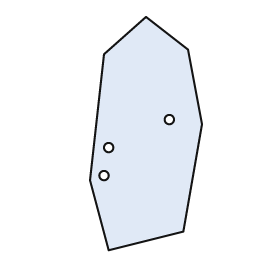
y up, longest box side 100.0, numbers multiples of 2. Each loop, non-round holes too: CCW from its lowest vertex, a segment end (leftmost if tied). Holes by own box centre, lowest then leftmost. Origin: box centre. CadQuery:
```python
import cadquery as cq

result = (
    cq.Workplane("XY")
    .moveTo(-16.0, -50.0)
    .lineTo(16.0, -42.0)
    .lineTo(24.0, 4.0)
    .lineTo(18.0, 36.0)
    .lineTo(0.0, 50.0)
    .lineTo(-18.0, 34.0)
    .lineTo(-24.0, -20.0)
    .close()
    .moveTo(-18.0, -18.0)
    .circle(2.0)
    .moveTo(-16.0, -6.0)
    .circle(2.0)
    .moveTo(10.0, 6.0)
    .circle(2.0)
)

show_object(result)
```